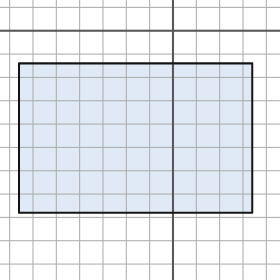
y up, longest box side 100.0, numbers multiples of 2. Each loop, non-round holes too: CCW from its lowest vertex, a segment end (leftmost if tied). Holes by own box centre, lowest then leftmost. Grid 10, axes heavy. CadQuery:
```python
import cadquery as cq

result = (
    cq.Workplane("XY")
    .moveTo(-66.0, -78.0)
    .lineTo(34.0, -78.0)
    .lineTo(34.0, -14.0)
    .lineTo(-66.0, -14.0)
    .close()
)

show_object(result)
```